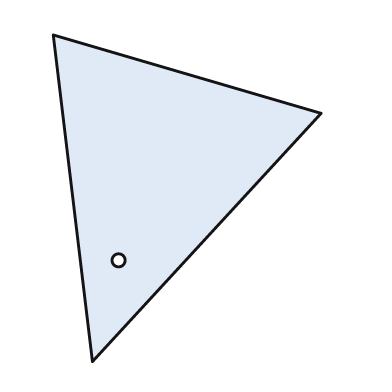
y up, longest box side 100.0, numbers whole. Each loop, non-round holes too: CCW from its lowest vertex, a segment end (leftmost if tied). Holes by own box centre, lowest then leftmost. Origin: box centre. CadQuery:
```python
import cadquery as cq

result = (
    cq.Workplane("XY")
    .moveTo(-29.0, -50.0)
    .lineTo(41.0, 26.0)
    .lineTo(-41.0, 50.0)
    .close()
    .moveTo(-21.0, -19.0)
    .circle(2.0)
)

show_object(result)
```